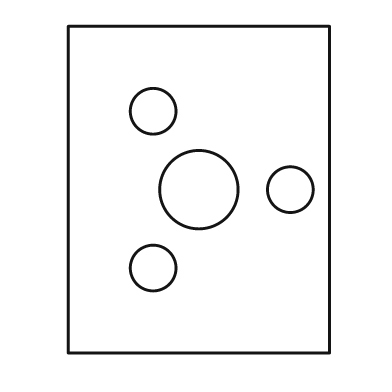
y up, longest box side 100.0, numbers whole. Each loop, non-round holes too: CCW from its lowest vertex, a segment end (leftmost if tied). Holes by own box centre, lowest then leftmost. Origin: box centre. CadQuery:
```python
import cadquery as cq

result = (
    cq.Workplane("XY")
    .moveTo(-40.0, -50.0)
    .lineTo(40.0, -50.0)
    .lineTo(40.0, 50.0)
    .lineTo(-40.0, 50.0)
    .close()
    .moveTo(-14.0, -24.0)
    .circle(7.0)
    .moveTo(0.0, 0.0)
    .circle(12.0)
    .moveTo(28.0, 0.0)
    .circle(7.0)
    .moveTo(-14.0, 24.0)
    .circle(7.0)
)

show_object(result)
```